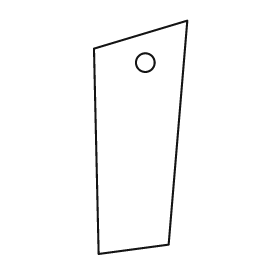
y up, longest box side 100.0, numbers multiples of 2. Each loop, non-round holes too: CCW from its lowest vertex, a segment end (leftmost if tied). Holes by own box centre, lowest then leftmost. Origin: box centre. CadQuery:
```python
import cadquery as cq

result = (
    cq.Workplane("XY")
    .moveTo(-18.0, -50.0)
    .lineTo(12.0, -46.0)
    .lineTo(20.0, 50.0)
    .lineTo(-20.0, 38.0)
    .close()
    .moveTo(2.0, 32.0)
    .circle(4.0)
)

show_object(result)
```